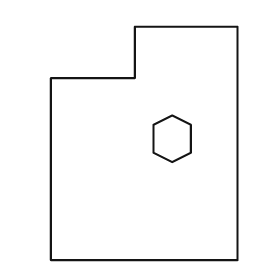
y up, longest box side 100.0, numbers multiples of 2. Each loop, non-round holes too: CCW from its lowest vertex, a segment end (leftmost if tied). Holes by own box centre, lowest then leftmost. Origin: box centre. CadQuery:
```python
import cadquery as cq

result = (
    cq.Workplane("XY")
    .moveTo(-40.0, -50.0)
    .lineTo(40.0, -50.0)
    .lineTo(40.0, 50.0)
    .lineTo(-4.0, 50.0)
    .lineTo(-4.0, 28.0)
    .lineTo(-40.0, 28.0)
    .close()
    .moveTo(12.0, -8.0)
    .lineTo(20.0, -4.0)
    .lineTo(20.0, 8.0)
    .lineTo(12.0, 12.0)
    .lineTo(4.0, 8.0)
    .lineTo(4.0, -4.0)
    .close()
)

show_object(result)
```